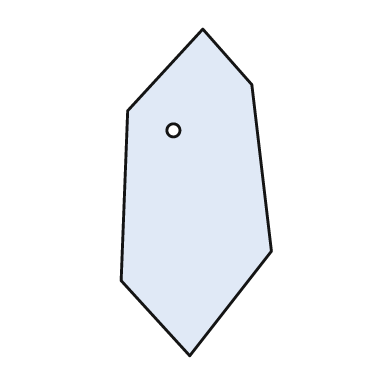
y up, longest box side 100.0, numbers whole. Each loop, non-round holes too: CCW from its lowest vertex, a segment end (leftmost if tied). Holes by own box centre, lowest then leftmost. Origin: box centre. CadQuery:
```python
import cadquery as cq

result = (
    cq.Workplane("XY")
    .moveTo(-2.0, -50.0)
    .lineTo(23.0, -18.0)
    .lineTo(17.0, 33.0)
    .lineTo(2.0, 50.0)
    .lineTo(-21.0, 25.0)
    .lineTo(-23.0, -27.0)
    .close()
    .moveTo(-7.0, 19.0)
    .circle(2.0)
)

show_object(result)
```